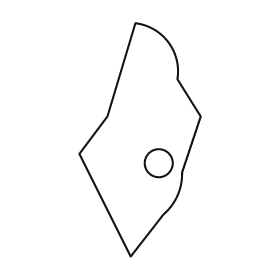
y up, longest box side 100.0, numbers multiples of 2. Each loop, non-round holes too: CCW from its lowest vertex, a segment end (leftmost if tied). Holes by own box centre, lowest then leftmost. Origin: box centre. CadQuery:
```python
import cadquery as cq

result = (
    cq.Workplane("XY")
    .moveTo(-4.0, -50.0)
    .lineTo(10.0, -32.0)
    .threePointArc((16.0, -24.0), (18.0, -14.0))
    .lineTo(26.0, 10.0)
    .lineTo(16.0, 26.0)
    .threePointArc((12.0, 42.0), (-2.0, 50.0))
    .lineTo(-14.0, 10.0)
    .lineTo(-26.0, -6.0)
    .close()
    .moveTo(8.0, -10.0)
    .circle(6.0)
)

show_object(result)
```